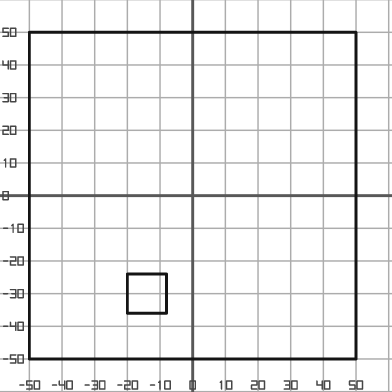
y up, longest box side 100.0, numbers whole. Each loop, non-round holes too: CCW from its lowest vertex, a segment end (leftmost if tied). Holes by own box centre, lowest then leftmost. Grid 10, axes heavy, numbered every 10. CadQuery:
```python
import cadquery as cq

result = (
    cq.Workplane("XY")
    .moveTo(-50.0, -50.0)
    .lineTo(50.0, -50.0)
    .lineTo(50.0, 50.0)
    .lineTo(-50.0, 50.0)
    .close()
    .moveTo(-20.0, -36.0)
    .lineTo(-8.0, -36.0)
    .lineTo(-8.0, -24.0)
    .lineTo(-20.0, -24.0)
    .close()
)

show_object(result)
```